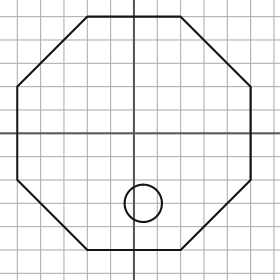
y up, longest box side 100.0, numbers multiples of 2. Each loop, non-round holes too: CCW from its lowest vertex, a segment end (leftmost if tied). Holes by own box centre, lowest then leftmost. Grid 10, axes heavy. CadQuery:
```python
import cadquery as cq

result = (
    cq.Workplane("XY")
    .moveTo(-20.0, -50.0)
    .lineTo(20.0, -50.0)
    .lineTo(50.0, -20.0)
    .lineTo(50.0, 20.0)
    .lineTo(20.0, 50.0)
    .lineTo(-20.0, 50.0)
    .lineTo(-50.0, 20.0)
    .lineTo(-50.0, -20.0)
    .close()
    .moveTo(4.0, -30.0)
    .circle(8.0)
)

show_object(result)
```